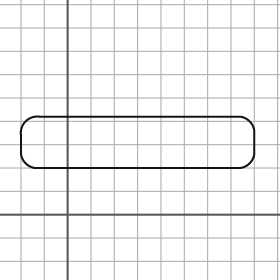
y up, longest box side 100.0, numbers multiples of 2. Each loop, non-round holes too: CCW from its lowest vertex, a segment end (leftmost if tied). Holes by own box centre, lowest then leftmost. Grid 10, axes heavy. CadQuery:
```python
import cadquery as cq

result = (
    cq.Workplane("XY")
    .moveTo(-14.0, 20.0)
    .lineTo(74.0, 20.0)
    .threePointArc((78.0, 22.0), (80.0, 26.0))
    .lineTo(80.0, 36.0)
    .threePointArc((78.0, 40.0), (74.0, 42.0))
    .lineTo(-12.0, 42.0)
    .threePointArc((-18.0, 40.0), (-20.0, 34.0))
    .lineTo(-20.0, 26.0)
    .threePointArc((-18.0, 22.0), (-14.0, 20.0))
    .close()
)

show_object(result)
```